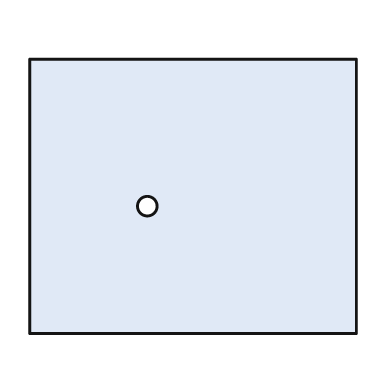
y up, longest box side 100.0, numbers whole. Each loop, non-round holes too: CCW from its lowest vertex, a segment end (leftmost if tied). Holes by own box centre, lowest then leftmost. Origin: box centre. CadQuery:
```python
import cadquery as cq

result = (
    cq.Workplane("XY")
    .moveTo(-50.0, -42.0)
    .lineTo(50.0, -42.0)
    .lineTo(50.0, 42.0)
    .lineTo(-50.0, 42.0)
    .close()
    .moveTo(-14.0, -3.0)
    .circle(3.0)
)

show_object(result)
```